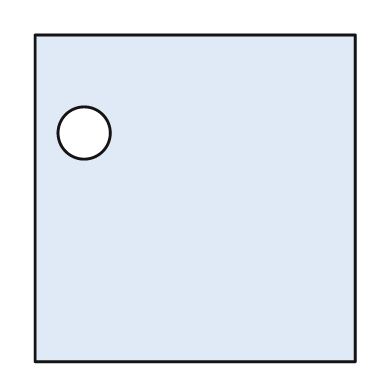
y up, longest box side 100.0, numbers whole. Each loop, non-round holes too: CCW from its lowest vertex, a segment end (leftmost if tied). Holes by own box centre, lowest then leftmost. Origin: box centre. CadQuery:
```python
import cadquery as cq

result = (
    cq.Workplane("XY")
    .moveTo(-49.0, -50.0)
    .lineTo(49.0, -50.0)
    .lineTo(49.0, 50.0)
    .lineTo(-49.0, 50.0)
    .close()
    .moveTo(-34.0, 20.0)
    .circle(8.0)
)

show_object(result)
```